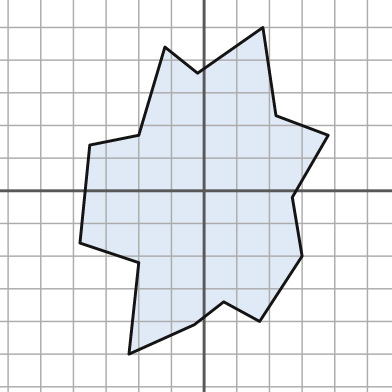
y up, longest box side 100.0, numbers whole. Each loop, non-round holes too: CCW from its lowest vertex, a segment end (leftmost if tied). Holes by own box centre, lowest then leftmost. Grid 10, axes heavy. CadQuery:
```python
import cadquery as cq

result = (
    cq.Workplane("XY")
    .moveTo(-23.0, -50.0)
    .lineTo(-3.0, -41.0)
    .lineTo(6.0, -34.0)
    .lineTo(17.0, -40.0)
    .lineTo(30.0, -20.0)
    .lineTo(27.0, -2.0)
    .lineTo(38.0, 17.0)
    .lineTo(22.0, 23.0)
    .lineTo(18.0, 50.0)
    .lineTo(-2.0, 36.0)
    .lineTo(-12.0, 44.0)
    .lineTo(-20.0, 17.0)
    .lineTo(-35.0, 14.0)
    .lineTo(-38.0, -16.0)
    .lineTo(-20.0, -22.0)
    .close()
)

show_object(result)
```